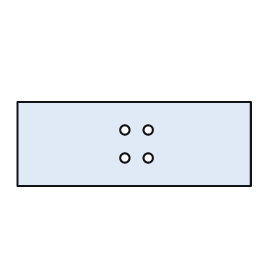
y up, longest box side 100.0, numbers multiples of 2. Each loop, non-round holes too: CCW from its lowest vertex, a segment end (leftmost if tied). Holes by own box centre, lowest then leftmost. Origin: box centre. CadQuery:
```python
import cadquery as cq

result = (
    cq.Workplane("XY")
    .moveTo(-50.0, -18.0)
    .lineTo(50.0, -18.0)
    .lineTo(50.0, 18.0)
    .lineTo(-50.0, 18.0)
    .close()
    .moveTo(-4.0, -6.0)
    .circle(2.0)
    .moveTo(6.0, -6.0)
    .circle(2.0)
    .moveTo(-4.0, 6.0)
    .circle(2.0)
    .moveTo(6.0, 6.0)
    .circle(2.0)
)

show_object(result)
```